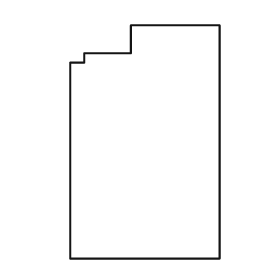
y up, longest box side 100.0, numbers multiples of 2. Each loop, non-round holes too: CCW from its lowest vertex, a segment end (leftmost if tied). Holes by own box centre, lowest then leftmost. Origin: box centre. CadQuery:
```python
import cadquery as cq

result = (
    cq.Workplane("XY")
    .moveTo(-32.0, -50.0)
    .lineTo(32.0, -50.0)
    .lineTo(32.0, 50.0)
    .lineTo(-6.0, 50.0)
    .lineTo(-6.0, 38.0)
    .lineTo(-26.0, 38.0)
    .lineTo(-26.0, 34.0)
    .lineTo(-32.0, 34.0)
    .close()
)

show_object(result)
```